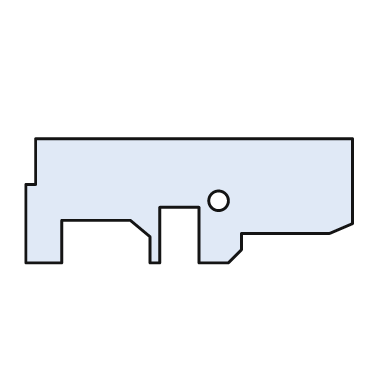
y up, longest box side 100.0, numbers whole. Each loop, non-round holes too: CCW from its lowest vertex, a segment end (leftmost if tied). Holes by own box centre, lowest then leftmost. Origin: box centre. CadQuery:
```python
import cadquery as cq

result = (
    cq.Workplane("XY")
    .moveTo(-50.0, -19.0)
    .lineTo(-39.0, -19.0)
    .lineTo(-39.0, -6.0)
    .lineTo(-18.0, -6.0)
    .lineTo(-12.0, -11.0)
    .lineTo(-12.0, -19.0)
    .lineTo(-9.0, -19.0)
    .lineTo(-9.0, -2.0)
    .lineTo(3.0, -2.0)
    .lineTo(3.0, -19.0)
    .lineTo(12.0, -19.0)
    .lineTo(16.0, -15.0)
    .lineTo(16.0, -10.0)
    .lineTo(43.0, -10.0)
    .lineTo(50.0, -7.0)
    .lineTo(50.0, 19.0)
    .lineTo(-47.0, 19.0)
    .lineTo(-47.0, 5.0)
    .lineTo(-50.0, 5.0)
    .close()
    .moveTo(9.0, 0.0)
    .circle(3.0)
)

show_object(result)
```